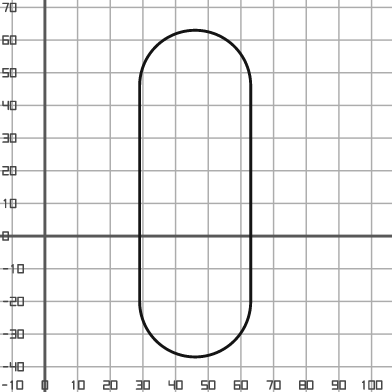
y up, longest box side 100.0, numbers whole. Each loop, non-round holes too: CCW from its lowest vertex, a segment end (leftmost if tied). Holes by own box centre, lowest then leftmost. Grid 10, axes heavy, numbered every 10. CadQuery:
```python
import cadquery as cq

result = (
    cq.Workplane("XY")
    .moveTo(29.0, -20.0)
    .threePointArc((46.0, -37.0), (63.0, -20.0))
    .lineTo(63.0, 46.0)
    .threePointArc((46.0, 63.0), (29.0, 46.0))
    .close()
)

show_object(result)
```